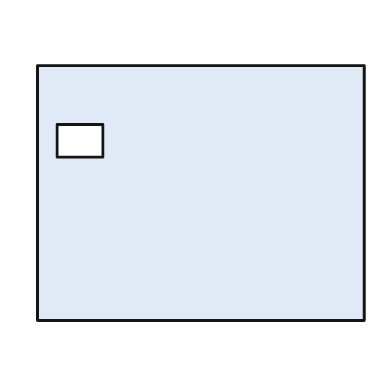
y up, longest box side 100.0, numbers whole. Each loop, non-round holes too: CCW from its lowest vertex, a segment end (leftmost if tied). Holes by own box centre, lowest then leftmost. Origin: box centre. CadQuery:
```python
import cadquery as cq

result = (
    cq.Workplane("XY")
    .moveTo(-50.0, -39.0)
    .lineTo(50.0, -39.0)
    .lineTo(50.0, 39.0)
    .lineTo(-50.0, 39.0)
    .close()
    .moveTo(-44.0, 11.0)
    .lineTo(-30.0, 11.0)
    .lineTo(-30.0, 21.0)
    .lineTo(-44.0, 21.0)
    .close()
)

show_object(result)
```